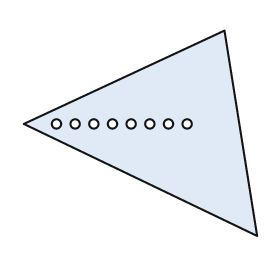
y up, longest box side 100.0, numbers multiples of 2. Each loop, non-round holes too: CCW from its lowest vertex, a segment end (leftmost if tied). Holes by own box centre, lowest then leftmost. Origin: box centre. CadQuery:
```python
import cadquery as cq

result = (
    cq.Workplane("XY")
    .moveTo(50.0, -44.0)
    .lineTo(36.0, 44.0)
    .lineTo(-50.0, 4.0)
    .close()
    .moveTo(-36.0, 4.0)
    .circle(2.0)
    .moveTo(-28.0, 4.0)
    .circle(2.0)
    .moveTo(-20.0, 4.0)
    .circle(2.0)
    .moveTo(-12.0, 4.0)
    .circle(2.0)
    .moveTo(-4.0, 4.0)
    .circle(2.0)
    .moveTo(4.0, 4.0)
    .circle(2.0)
    .moveTo(12.0, 4.0)
    .circle(2.0)
    .moveTo(20.0, 4.0)
    .circle(2.0)
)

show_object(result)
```